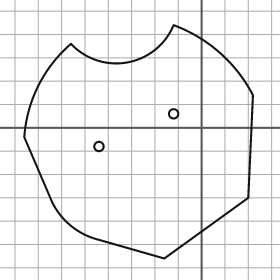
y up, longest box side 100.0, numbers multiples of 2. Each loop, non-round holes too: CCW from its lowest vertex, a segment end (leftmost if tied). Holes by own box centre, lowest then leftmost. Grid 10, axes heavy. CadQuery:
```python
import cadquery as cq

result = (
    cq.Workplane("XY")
    .moveTo(-16.0, -56.0)
    .lineTo(20.0, -30.0)
    .lineTo(22.0, 14.0)
    .threePointArc((8.0, 32.0), (-12.0, 44.0))
    .threePointArc((-32.0, 28.0), (-56.0, 36.0))
    .threePointArc((-70.0, 18.0), (-76.0, -4.0))
    .lineTo(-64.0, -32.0)
    .threePointArc((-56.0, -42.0), (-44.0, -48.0))
    .close()
    .moveTo(-44.0, -8.0)
    .circle(2.0)
    .moveTo(-12.0, 6.0)
    .circle(2.0)
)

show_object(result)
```